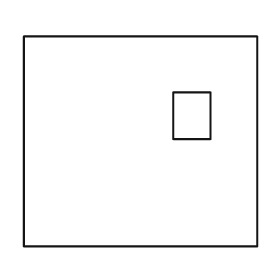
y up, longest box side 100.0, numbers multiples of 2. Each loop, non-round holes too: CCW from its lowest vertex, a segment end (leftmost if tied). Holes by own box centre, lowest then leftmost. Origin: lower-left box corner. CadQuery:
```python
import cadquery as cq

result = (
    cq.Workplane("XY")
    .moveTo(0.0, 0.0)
    .lineTo(100.0, 0.0)
    .lineTo(100.0, 90.0)
    .lineTo(0.0, 90.0)
    .close()
    .moveTo(64.0, 46.0)
    .lineTo(80.0, 46.0)
    .lineTo(80.0, 66.0)
    .lineTo(64.0, 66.0)
    .close()
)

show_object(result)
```